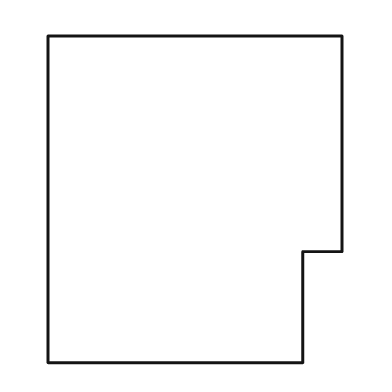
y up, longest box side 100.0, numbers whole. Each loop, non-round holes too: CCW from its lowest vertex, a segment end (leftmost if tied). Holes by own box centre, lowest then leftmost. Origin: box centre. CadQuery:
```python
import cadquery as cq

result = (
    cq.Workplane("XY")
    .moveTo(-45.0, -50.0)
    .lineTo(33.0, -50.0)
    .lineTo(33.0, -16.0)
    .lineTo(45.0, -16.0)
    .lineTo(45.0, 50.0)
    .lineTo(-45.0, 50.0)
    .close()
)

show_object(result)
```